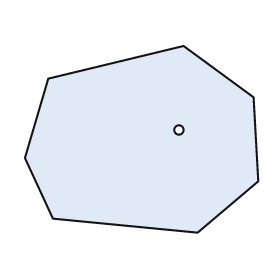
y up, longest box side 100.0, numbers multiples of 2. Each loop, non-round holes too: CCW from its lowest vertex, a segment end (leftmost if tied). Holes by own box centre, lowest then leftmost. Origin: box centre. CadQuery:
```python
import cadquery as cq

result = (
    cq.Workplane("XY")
    .moveTo(24.0, -40.0)
    .lineTo(50.0, -18.0)
    .lineTo(48.0, 18.0)
    .lineTo(18.0, 40.0)
    .lineTo(-40.0, 26.0)
    .lineTo(-50.0, -8.0)
    .lineTo(-38.0, -34.0)
    .close()
    .moveTo(16.0, 4.0)
    .circle(2.0)
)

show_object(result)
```